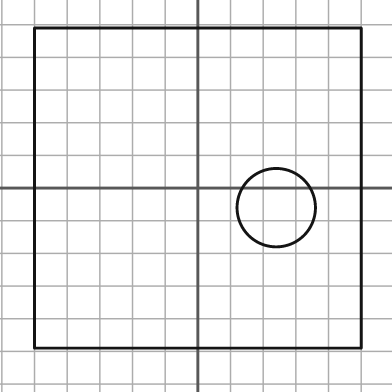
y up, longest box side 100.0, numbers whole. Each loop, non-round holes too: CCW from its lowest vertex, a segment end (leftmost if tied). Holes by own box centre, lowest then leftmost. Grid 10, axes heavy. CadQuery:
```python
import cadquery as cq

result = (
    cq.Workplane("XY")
    .moveTo(-50.0, -49.0)
    .lineTo(50.0, -49.0)
    .lineTo(50.0, 49.0)
    .lineTo(-50.0, 49.0)
    .close()
    .moveTo(24.0, -6.0)
    .circle(12.0)
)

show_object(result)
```